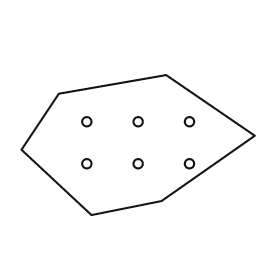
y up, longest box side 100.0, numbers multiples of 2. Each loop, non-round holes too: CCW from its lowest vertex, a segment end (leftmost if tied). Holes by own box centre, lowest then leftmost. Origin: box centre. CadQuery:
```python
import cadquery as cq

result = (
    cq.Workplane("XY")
    .moveTo(-20.0, -30.0)
    .lineTo(10.0, -24.0)
    .lineTo(50.0, 4.0)
    .lineTo(12.0, 30.0)
    .lineTo(-34.0, 22.0)
    .lineTo(-50.0, -2.0)
    .close()
    .moveTo(-22.0, -8.0)
    .circle(2.0)
    .moveTo(0.0, -8.0)
    .circle(2.0)
    .moveTo(22.0, -8.0)
    .circle(2.0)
    .moveTo(-22.0, 10.0)
    .circle(2.0)
    .moveTo(0.0, 10.0)
    .circle(2.0)
    .moveTo(22.0, 10.0)
    .circle(2.0)
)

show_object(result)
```